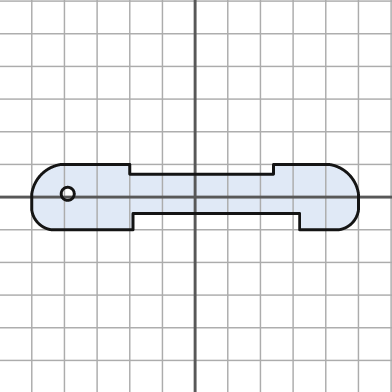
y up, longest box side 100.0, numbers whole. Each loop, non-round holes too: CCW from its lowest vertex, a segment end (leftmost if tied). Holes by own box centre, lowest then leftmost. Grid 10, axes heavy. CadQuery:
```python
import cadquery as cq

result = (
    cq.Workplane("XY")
    .moveTo(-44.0, -10.0)
    .lineTo(-19.0, -10.0)
    .lineTo(-19.0, -5.0)
    .lineTo(32.0, -5.0)
    .lineTo(32.0, -10.0)
    .lineTo(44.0, -10.0)
    .threePointArc((48.0, -8.0), (50.0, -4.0))
    .lineTo(50.0, 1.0)
    .threePointArc((47.0, 7.0), (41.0, 10.0))
    .lineTo(24.0, 10.0)
    .lineTo(24.0, 7.0)
    .lineTo(-20.0, 7.0)
    .lineTo(-20.0, 10.0)
    .lineTo(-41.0, 10.0)
    .threePointArc((-47.0, 7.0), (-50.0, 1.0))
    .lineTo(-50.0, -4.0)
    .threePointArc((-48.0, -8.0), (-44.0, -10.0))
    .close()
    .moveTo(-39.0, 1.0)
    .circle(2.0)
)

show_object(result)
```